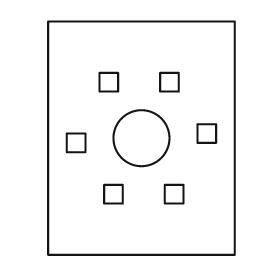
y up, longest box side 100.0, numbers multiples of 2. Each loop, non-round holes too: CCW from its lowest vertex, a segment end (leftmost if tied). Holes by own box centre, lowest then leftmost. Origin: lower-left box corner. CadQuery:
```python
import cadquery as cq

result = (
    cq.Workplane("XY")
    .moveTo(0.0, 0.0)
    .lineTo(80.0, 0.0)
    .lineTo(80.0, 100.0)
    .lineTo(0.0, 100.0)
    .close()
    .moveTo(24.0, 22.0)
    .lineTo(32.0, 22.0)
    .lineTo(32.0, 30.0)
    .lineTo(24.0, 30.0)
    .close()
    .moveTo(50.0, 22.0)
    .lineTo(58.0, 22.0)
    .lineTo(58.0, 30.0)
    .lineTo(50.0, 30.0)
    .close()
    .moveTo(8.0, 44.0)
    .lineTo(16.0, 44.0)
    .lineTo(16.0, 52.0)
    .lineTo(8.0, 52.0)
    .close()
    .moveTo(40.0, 50.0)
    .circle(12.0)
    .moveTo(64.0, 48.0)
    .lineTo(72.0, 48.0)
    .lineTo(72.0, 56.0)
    .lineTo(64.0, 56.0)
    .close()
    .moveTo(22.0, 70.0)
    .lineTo(30.0, 70.0)
    .lineTo(30.0, 78.0)
    .lineTo(22.0, 78.0)
    .close()
    .moveTo(48.0, 70.0)
    .lineTo(56.0, 70.0)
    .lineTo(56.0, 78.0)
    .lineTo(48.0, 78.0)
    .close()
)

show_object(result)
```